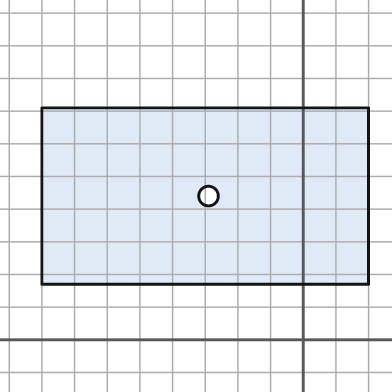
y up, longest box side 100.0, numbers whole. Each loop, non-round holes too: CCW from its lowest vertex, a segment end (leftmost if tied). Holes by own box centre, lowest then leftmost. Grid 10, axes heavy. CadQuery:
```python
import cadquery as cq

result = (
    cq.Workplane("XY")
    .moveTo(-80.0, 17.0)
    .lineTo(20.0, 17.0)
    .lineTo(20.0, 71.0)
    .lineTo(-80.0, 71.0)
    .close()
    .moveTo(-29.0, 44.0)
    .circle(3.0)
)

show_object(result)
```